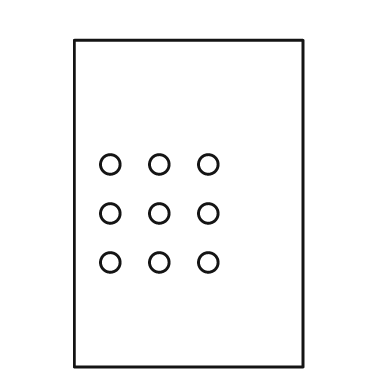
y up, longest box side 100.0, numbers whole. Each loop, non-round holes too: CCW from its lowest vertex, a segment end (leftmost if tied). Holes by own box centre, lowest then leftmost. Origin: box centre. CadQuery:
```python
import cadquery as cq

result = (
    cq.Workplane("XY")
    .moveTo(-35.0, -50.0)
    .lineTo(35.0, -50.0)
    .lineTo(35.0, 50.0)
    .lineTo(-35.0, 50.0)
    .close()
    .moveTo(-24.0, -18.0)
    .circle(3.0)
    .moveTo(-9.0, -18.0)
    .circle(3.0)
    .moveTo(6.0, -18.0)
    .circle(3.0)
    .moveTo(-24.0, -3.0)
    .circle(3.0)
    .moveTo(-9.0, -3.0)
    .circle(3.0)
    .moveTo(6.0, -3.0)
    .circle(3.0)
    .moveTo(-24.0, 12.0)
    .circle(3.0)
    .moveTo(-9.0, 12.0)
    .circle(3.0)
    .moveTo(6.0, 12.0)
    .circle(3.0)
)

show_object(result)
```